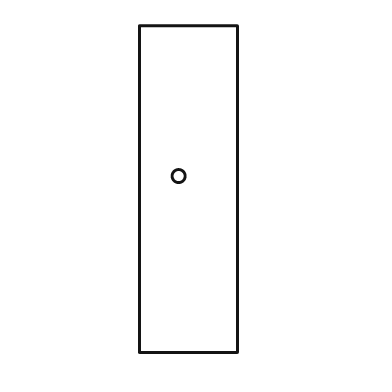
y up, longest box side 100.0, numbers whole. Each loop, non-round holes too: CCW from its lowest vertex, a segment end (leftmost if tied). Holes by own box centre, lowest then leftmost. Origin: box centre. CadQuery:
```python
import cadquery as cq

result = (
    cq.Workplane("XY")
    .moveTo(-15.0, -50.0)
    .lineTo(15.0, -50.0)
    .lineTo(15.0, 50.0)
    .lineTo(-15.0, 50.0)
    .close()
    .moveTo(-3.0, 4.0)
    .circle(2.0)
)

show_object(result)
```